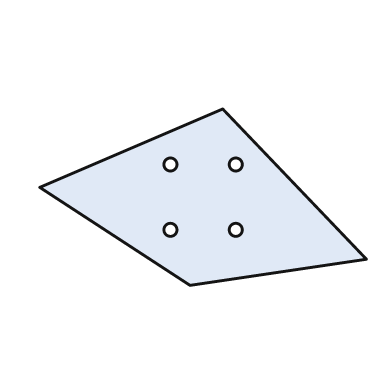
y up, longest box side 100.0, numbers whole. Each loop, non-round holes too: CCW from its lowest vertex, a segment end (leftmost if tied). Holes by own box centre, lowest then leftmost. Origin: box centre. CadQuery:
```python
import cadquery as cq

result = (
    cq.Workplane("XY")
    .moveTo(-4.0, -27.0)
    .lineTo(50.0, -19.0)
    .lineTo(6.0, 27.0)
    .lineTo(-50.0, 3.0)
    .close()
    .moveTo(-10.0, -10.0)
    .circle(2.0)
    .moveTo(10.0, -10.0)
    .circle(2.0)
    .moveTo(-10.0, 10.0)
    .circle(2.0)
    .moveTo(10.0, 10.0)
    .circle(2.0)
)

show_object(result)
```